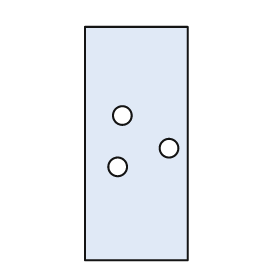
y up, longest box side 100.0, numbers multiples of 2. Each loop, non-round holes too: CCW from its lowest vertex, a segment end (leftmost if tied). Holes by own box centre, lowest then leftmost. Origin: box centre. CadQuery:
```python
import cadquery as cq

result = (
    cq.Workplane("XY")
    .moveTo(-22.0, -50.0)
    .lineTo(22.0, -50.0)
    .lineTo(22.0, 50.0)
    .lineTo(-22.0, 50.0)
    .close()
    .moveTo(-8.0, -10.0)
    .circle(4.0)
    .moveTo(14.0, -2.0)
    .circle(4.0)
    .moveTo(-6.0, 12.0)
    .circle(4.0)
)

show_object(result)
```